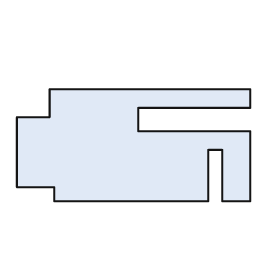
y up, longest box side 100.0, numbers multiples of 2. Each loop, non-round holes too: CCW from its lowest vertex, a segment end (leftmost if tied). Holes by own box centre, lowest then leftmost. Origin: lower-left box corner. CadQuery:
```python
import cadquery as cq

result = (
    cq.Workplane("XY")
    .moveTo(16.0, 0.0)
    .lineTo(82.0, 0.0)
    .lineTo(82.0, 22.0)
    .lineTo(88.0, 22.0)
    .lineTo(88.0, 0.0)
    .lineTo(100.0, 0.0)
    .lineTo(100.0, 30.0)
    .lineTo(52.0, 30.0)
    .lineTo(52.0, 40.0)
    .lineTo(100.0, 40.0)
    .lineTo(100.0, 48.0)
    .lineTo(14.0, 48.0)
    .lineTo(14.0, 36.0)
    .lineTo(0.0, 36.0)
    .lineTo(0.0, 6.0)
    .lineTo(16.0, 6.0)
    .close()
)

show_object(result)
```